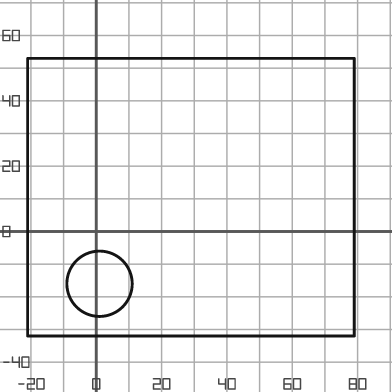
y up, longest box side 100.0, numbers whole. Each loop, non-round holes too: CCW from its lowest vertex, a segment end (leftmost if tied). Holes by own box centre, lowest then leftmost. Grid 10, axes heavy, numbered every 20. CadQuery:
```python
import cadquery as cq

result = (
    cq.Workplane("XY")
    .moveTo(-21.0, -32.0)
    .lineTo(79.0, -32.0)
    .lineTo(79.0, 53.0)
    .lineTo(-21.0, 53.0)
    .close()
    .moveTo(1.0, -16.0)
    .circle(10.0)
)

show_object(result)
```